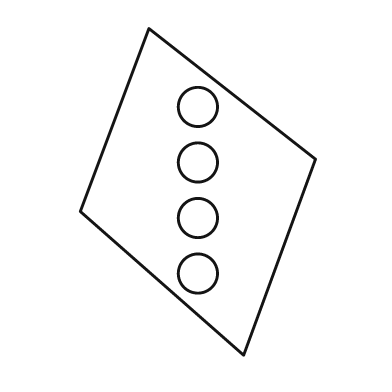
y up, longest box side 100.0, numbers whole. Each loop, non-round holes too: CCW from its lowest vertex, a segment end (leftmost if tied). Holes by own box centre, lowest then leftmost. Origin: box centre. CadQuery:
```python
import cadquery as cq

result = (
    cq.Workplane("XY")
    .moveTo(14.0, -50.0)
    .lineTo(36.0, 10.0)
    .lineTo(-15.0, 50.0)
    .lineTo(-36.0, -6.0)
    .close()
    .moveTo(0.0, -25.0)
    .circle(6.0)
    .moveTo(0.0, -8.0)
    .circle(6.0)
    .moveTo(0.0, 9.0)
    .circle(6.0)
    .moveTo(0.0, 26.0)
    .circle(6.0)
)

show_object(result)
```